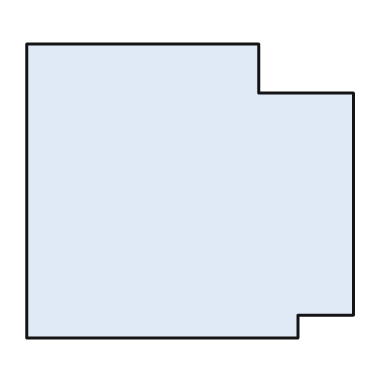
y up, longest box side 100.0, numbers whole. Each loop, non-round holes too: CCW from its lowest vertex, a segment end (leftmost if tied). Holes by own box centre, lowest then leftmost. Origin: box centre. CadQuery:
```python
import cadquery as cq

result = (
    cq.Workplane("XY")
    .moveTo(-50.0, -45.0)
    .lineTo(33.0, -45.0)
    .lineTo(33.0, -38.0)
    .lineTo(50.0, -38.0)
    .lineTo(50.0, 30.0)
    .lineTo(21.0, 30.0)
    .lineTo(21.0, 45.0)
    .lineTo(-50.0, 45.0)
    .close()
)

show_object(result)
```